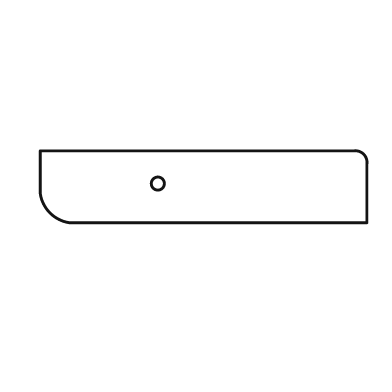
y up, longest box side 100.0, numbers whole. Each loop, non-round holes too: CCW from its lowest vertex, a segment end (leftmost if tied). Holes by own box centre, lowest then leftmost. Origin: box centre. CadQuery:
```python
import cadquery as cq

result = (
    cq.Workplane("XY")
    .moveTo(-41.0, -11.0)
    .lineTo(50.0, -11.0)
    .lineTo(50.0, 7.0)
    .threePointArc((49.0, 10.0), (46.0, 11.0))
    .lineTo(-50.0, 11.0)
    .lineTo(-50.0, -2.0)
    .threePointArc((-47.0, -8.0), (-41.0, -11.0))
    .close()
    .moveTo(-14.0, 1.0)
    .circle(2.0)
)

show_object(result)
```